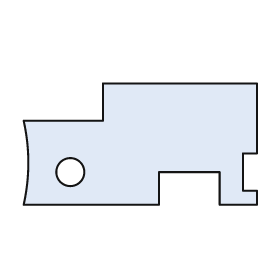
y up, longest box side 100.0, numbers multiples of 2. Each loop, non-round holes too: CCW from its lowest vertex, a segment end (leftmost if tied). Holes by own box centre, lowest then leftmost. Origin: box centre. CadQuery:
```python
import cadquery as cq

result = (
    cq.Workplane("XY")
    .moveTo(-50.0, -26.0)
    .lineTo(8.0, -26.0)
    .lineTo(8.0, -12.0)
    .lineTo(34.0, -12.0)
    .lineTo(34.0, -26.0)
    .lineTo(50.0, -26.0)
    .lineTo(50.0, -20.0)
    .lineTo(44.0, -20.0)
    .lineTo(44.0, -4.0)
    .lineTo(50.0, -4.0)
    .lineTo(50.0, 26.0)
    .lineTo(-16.0, 26.0)
    .lineTo(-16.0, 10.0)
    .lineTo(-50.0, 10.0)
    .threePointArc((-48.0, -8.0), (-50.0, -26.0))
    .close()
    .moveTo(-30.0, -12.0)
    .circle(6.0)
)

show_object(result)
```